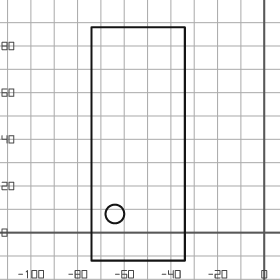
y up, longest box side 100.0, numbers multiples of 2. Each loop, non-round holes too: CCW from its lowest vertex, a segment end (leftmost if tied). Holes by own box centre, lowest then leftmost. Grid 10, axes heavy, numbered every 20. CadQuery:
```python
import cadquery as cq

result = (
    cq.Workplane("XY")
    .moveTo(-74.0, -12.0)
    .lineTo(-34.0, -12.0)
    .lineTo(-34.0, 88.0)
    .lineTo(-74.0, 88.0)
    .close()
    .moveTo(-64.0, 8.0)
    .circle(4.0)
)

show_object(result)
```